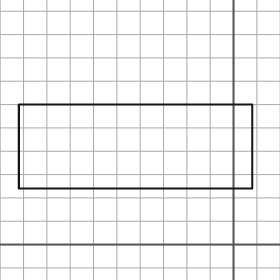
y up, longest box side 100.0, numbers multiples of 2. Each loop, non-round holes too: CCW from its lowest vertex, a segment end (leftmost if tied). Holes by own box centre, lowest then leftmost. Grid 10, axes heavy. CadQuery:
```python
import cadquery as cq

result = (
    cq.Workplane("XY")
    .moveTo(-92.0, 24.0)
    .lineTo(8.0, 24.0)
    .lineTo(8.0, 60.0)
    .lineTo(-92.0, 60.0)
    .close()
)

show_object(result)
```